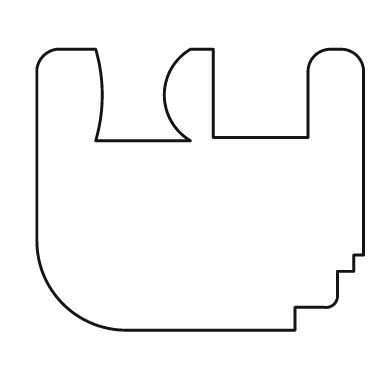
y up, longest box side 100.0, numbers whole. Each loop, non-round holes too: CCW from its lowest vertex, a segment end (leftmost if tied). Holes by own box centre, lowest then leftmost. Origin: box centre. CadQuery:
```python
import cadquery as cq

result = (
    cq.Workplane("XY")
    .moveTo(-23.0, -43.0)
    .lineTo(29.0, -43.0)
    .lineTo(29.0, -36.0)
    .lineTo(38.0, -36.0)
    .threePointArc((41.0, -35.0), (42.0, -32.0))
    .lineTo(42.0, -25.0)
    .lineTo(47.0, -25.0)
    .lineTo(47.0, -20.0)
    .lineTo(50.0, -20.0)
    .lineTo(50.0, 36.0)
    .threePointArc((48.0, 41.0), (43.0, 43.0))
    .lineTo(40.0, 43.0)
    .threePointArc((35.0, 41.0), (33.0, 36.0))
    .lineTo(33.0, 16.0)
    .lineTo(4.0, 16.0)
    .lineTo(4.0, 43.0)
    .lineTo(-3.0, 43.0)
    .threePointArc((-11.0, 29.0), (-3.0, 15.0))
    .lineTo(-32.0, 15.0)
    .threePointArc((-30.0, 29.0), (-32.0, 43.0))
    .lineTo(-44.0, 43.0)
    .threePointArc((-48.0, 41.0), (-50.0, 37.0))
    .lineTo(-50.0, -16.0)
    .threePointArc((-42.0, -35.0), (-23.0, -43.0))
    .close()
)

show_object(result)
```